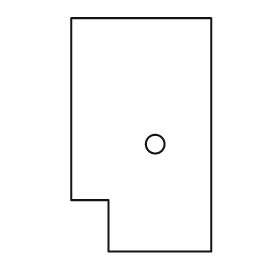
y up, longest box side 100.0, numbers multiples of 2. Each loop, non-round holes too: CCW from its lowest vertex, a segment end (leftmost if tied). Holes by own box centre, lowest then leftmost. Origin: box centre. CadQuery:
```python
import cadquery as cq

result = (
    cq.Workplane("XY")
    .moveTo(-14.0, -50.0)
    .lineTo(30.0, -50.0)
    .lineTo(30.0, 50.0)
    .lineTo(-30.0, 50.0)
    .lineTo(-30.0, -28.0)
    .lineTo(-14.0, -28.0)
    .close()
    .moveTo(6.0, -4.0)
    .circle(4.0)
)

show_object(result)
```